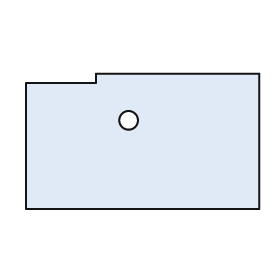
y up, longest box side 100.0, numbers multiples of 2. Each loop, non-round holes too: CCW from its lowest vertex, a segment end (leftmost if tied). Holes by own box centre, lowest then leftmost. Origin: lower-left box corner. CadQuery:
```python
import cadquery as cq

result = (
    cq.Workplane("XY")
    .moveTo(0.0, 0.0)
    .lineTo(100.0, 0.0)
    .lineTo(100.0, 58.0)
    .lineTo(30.0, 58.0)
    .lineTo(30.0, 54.0)
    .lineTo(0.0, 54.0)
    .close()
    .moveTo(44.0, 38.0)
    .circle(4.0)
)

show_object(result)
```